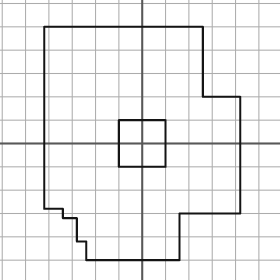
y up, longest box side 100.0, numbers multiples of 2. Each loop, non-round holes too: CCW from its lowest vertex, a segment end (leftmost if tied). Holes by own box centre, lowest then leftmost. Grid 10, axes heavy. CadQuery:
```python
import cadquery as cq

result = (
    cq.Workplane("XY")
    .moveTo(-24.0, -50.0)
    .lineTo(16.0, -50.0)
    .lineTo(16.0, -30.0)
    .lineTo(42.0, -30.0)
    .lineTo(42.0, 20.0)
    .lineTo(26.0, 20.0)
    .lineTo(26.0, 50.0)
    .lineTo(-42.0, 50.0)
    .lineTo(-42.0, -28.0)
    .lineTo(-34.0, -28.0)
    .lineTo(-34.0, -32.0)
    .lineTo(-28.0, -32.0)
    .lineTo(-28.0, -42.0)
    .lineTo(-24.0, -42.0)
    .close()
    .moveTo(-10.0, -10.0)
    .lineTo(10.0, -10.0)
    .lineTo(10.0, 10.0)
    .lineTo(-10.0, 10.0)
    .close()
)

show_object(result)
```